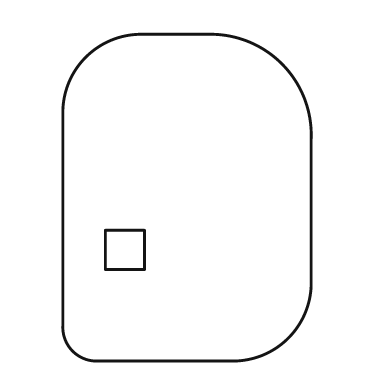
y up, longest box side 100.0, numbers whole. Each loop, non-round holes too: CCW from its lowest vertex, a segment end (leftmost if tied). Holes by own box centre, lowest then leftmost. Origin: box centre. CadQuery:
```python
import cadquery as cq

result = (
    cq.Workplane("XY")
    .moveTo(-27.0, -50.0)
    .lineTo(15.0, -50.0)
    .threePointArc((31.0, -43.0), (38.0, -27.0))
    .lineTo(38.0, 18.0)
    .threePointArc((29.0, 41.0), (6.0, 50.0))
    .lineTo(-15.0, 50.0)
    .threePointArc((-31.0, 43.0), (-38.0, 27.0))
    .lineTo(-38.0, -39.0)
    .threePointArc((-35.0, -47.0), (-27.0, -50.0))
    .close()
    .moveTo(-25.0, -22.0)
    .lineTo(-13.0, -22.0)
    .lineTo(-13.0, -10.0)
    .lineTo(-25.0, -10.0)
    .close()
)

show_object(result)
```